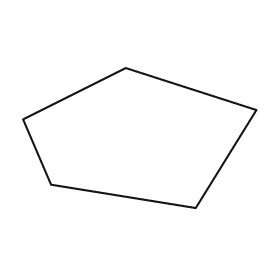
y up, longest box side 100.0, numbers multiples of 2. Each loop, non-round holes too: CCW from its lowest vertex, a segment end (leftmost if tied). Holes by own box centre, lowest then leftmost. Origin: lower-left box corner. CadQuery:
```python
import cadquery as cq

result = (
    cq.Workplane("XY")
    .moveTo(74.0, 0.0)
    .lineTo(100.0, 42.0)
    .lineTo(44.0, 60.0)
    .lineTo(0.0, 38.0)
    .lineTo(12.0, 10.0)
    .close()
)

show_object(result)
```